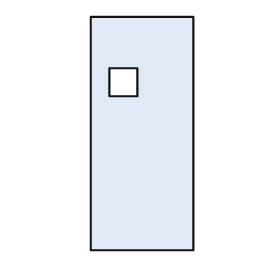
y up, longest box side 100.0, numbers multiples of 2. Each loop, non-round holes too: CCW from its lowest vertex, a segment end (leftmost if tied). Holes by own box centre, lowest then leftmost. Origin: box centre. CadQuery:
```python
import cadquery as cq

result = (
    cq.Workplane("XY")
    .moveTo(-22.0, -50.0)
    .lineTo(22.0, -50.0)
    .lineTo(22.0, 50.0)
    .lineTo(-22.0, 50.0)
    .close()
    .moveTo(-14.0, 16.0)
    .lineTo(-2.0, 16.0)
    .lineTo(-2.0, 28.0)
    .lineTo(-14.0, 28.0)
    .close()
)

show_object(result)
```